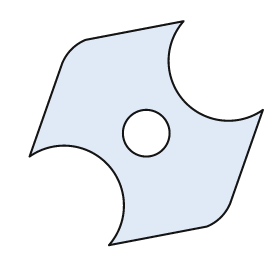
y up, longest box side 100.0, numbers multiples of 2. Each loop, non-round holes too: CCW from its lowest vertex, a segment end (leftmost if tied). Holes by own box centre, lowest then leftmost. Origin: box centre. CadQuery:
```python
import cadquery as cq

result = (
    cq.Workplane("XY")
    .moveTo(-16.0, -48.0)
    .lineTo(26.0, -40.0)
    .threePointArc((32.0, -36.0), (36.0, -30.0))
    .lineTo(50.0, 10.0)
    .threePointArc((16.0, 14.0), (16.0, 48.0))
    .lineTo(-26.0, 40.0)
    .threePointArc((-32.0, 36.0), (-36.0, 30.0))
    .lineTo(-50.0, -10.0)
    .threePointArc((-16.0, -14.0), (-16.0, -48.0))
    .close()
    .moveTo(0.0, 0.0)
    .circle(10.0)
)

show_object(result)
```